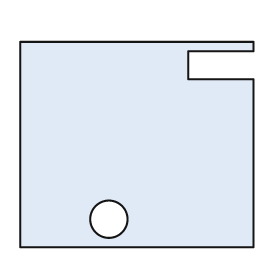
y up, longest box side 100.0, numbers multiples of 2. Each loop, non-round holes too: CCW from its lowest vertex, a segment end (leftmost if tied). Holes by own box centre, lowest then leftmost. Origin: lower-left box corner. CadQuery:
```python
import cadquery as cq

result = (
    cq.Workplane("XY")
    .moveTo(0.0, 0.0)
    .lineTo(100.0, 0.0)
    .lineTo(100.0, 72.0)
    .lineTo(72.0, 72.0)
    .lineTo(72.0, 84.0)
    .lineTo(100.0, 84.0)
    .lineTo(100.0, 88.0)
    .lineTo(0.0, 88.0)
    .close()
    .moveTo(38.0, 12.0)
    .circle(8.0)
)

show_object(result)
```